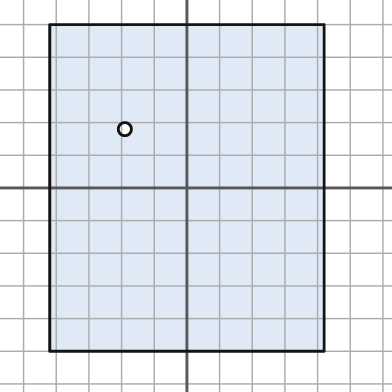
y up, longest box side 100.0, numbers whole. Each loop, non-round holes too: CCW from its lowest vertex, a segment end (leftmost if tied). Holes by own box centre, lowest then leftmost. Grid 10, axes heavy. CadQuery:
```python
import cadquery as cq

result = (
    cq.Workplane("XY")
    .moveTo(-42.0, -50.0)
    .lineTo(42.0, -50.0)
    .lineTo(42.0, 50.0)
    .lineTo(-42.0, 50.0)
    .close()
    .moveTo(-19.0, 18.0)
    .circle(2.0)
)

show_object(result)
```